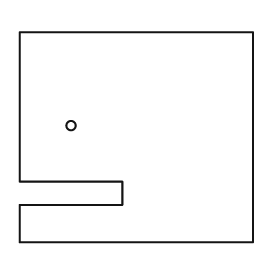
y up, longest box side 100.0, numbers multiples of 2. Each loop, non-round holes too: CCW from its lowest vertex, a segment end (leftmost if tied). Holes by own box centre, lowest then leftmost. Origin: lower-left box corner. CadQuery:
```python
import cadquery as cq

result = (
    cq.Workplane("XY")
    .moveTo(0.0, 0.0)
    .lineTo(100.0, 0.0)
    .lineTo(100.0, 90.0)
    .lineTo(0.0, 90.0)
    .lineTo(0.0, 26.0)
    .lineTo(44.0, 26.0)
    .lineTo(44.0, 16.0)
    .lineTo(0.0, 16.0)
    .close()
    .moveTo(22.0, 50.0)
    .circle(2.0)
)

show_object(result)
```